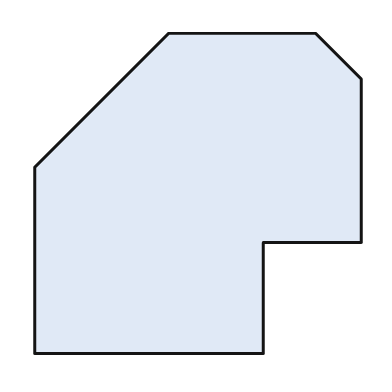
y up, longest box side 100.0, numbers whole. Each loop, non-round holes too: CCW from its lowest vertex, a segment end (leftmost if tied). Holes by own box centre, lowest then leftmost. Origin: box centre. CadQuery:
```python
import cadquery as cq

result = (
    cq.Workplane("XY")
    .moveTo(-50.0, -49.0)
    .lineTo(20.0, -49.0)
    .lineTo(20.0, -15.0)
    .lineTo(50.0, -15.0)
    .lineTo(50.0, 35.0)
    .lineTo(36.0, 49.0)
    .lineTo(-9.0, 49.0)
    .lineTo(-50.0, 8.0)
    .close()
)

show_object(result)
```